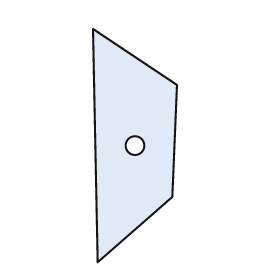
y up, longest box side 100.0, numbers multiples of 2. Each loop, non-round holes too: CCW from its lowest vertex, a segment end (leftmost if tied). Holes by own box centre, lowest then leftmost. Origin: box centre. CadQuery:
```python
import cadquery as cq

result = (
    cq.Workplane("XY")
    .moveTo(-16.0, -50.0)
    .lineTo(16.0, -22.0)
    .lineTo(18.0, 26.0)
    .lineTo(-18.0, 50.0)
    .close()
    .moveTo(0.0, 0.0)
    .circle(4.0)
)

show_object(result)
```